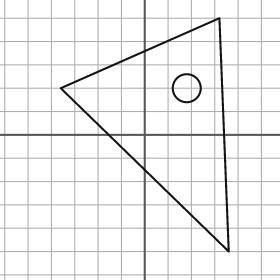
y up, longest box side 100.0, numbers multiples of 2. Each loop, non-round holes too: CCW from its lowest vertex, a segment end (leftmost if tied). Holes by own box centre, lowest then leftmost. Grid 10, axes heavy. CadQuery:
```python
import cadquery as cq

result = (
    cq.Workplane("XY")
    .moveTo(36.0, -50.0)
    .lineTo(32.0, 50.0)
    .lineTo(-36.0, 20.0)
    .close()
    .moveTo(18.0, 20.0)
    .circle(6.0)
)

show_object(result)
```